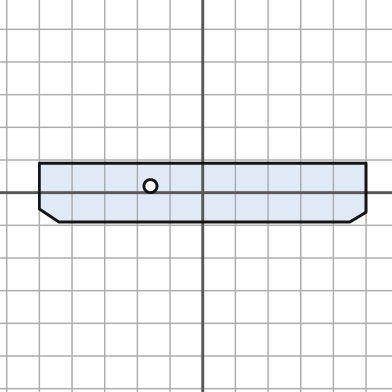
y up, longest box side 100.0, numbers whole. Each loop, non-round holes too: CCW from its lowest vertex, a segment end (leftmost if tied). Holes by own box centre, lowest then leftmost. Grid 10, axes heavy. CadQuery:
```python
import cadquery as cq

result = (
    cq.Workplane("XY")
    .moveTo(-44.0, -9.0)
    .lineTo(45.0, -9.0)
    .lineTo(50.0, -6.0)
    .lineTo(50.0, 9.0)
    .lineTo(-50.0, 9.0)
    .lineTo(-50.0, -5.0)
    .close()
    .moveTo(-16.0, 2.0)
    .circle(2.0)
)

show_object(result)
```